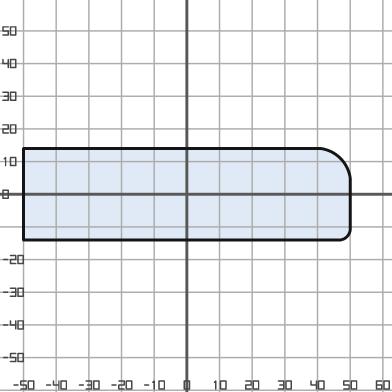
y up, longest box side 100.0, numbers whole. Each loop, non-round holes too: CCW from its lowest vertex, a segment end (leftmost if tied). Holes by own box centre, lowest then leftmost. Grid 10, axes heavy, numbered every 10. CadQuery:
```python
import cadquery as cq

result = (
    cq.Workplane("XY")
    .moveTo(-50.0, -14.0)
    .lineTo(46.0, -14.0)
    .threePointArc((49.0, -13.0), (50.0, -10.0))
    .lineTo(50.0, 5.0)
    .threePointArc((47.0, 11.0), (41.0, 14.0))
    .lineTo(-50.0, 14.0)
    .close()
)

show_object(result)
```